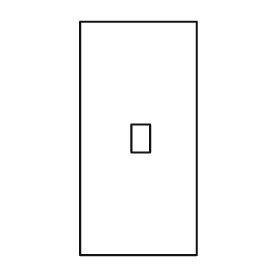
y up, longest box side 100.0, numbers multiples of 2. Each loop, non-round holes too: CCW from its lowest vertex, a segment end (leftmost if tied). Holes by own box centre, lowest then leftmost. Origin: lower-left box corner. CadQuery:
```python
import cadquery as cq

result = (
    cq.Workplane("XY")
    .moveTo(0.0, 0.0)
    .lineTo(50.0, 0.0)
    .lineTo(50.0, 100.0)
    .lineTo(0.0, 100.0)
    .close()
    .moveTo(22.0, 44.0)
    .lineTo(30.0, 44.0)
    .lineTo(30.0, 56.0)
    .lineTo(22.0, 56.0)
    .close()
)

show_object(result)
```